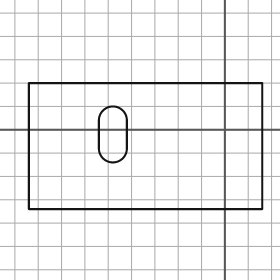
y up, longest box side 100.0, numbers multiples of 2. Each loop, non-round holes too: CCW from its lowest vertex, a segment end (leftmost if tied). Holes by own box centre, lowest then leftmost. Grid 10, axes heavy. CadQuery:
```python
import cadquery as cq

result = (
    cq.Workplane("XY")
    .moveTo(-84.0, -34.0)
    .lineTo(16.0, -34.0)
    .lineTo(16.0, 20.0)
    .lineTo(-84.0, 20.0)
    .close()
    .moveTo(-54.0, -8.0)
    .threePointArc((-48.0, -14.0), (-42.0, -8.0))
    .lineTo(-42.0, 4.0)
    .threePointArc((-48.0, 10.0), (-54.0, 4.0))
    .close()
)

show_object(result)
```